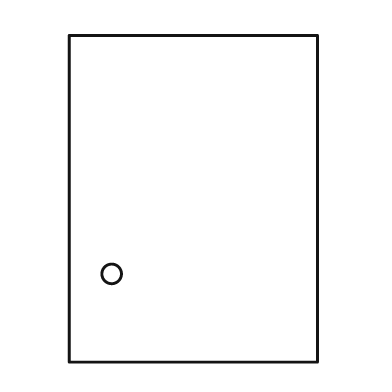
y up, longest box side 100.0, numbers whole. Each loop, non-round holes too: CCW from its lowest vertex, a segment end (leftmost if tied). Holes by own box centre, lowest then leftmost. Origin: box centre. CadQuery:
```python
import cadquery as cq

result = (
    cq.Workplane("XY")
    .moveTo(-38.0, -50.0)
    .lineTo(38.0, -50.0)
    .lineTo(38.0, 50.0)
    .lineTo(-38.0, 50.0)
    .close()
    .moveTo(-25.0, -23.0)
    .circle(3.0)
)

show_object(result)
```